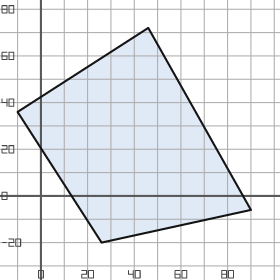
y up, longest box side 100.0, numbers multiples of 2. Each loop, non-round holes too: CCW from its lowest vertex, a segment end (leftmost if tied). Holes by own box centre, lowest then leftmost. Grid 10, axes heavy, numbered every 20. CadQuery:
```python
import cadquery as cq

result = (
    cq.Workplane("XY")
    .moveTo(26.0, -20.0)
    .lineTo(90.0, -6.0)
    .lineTo(46.0, 72.0)
    .lineTo(-10.0, 36.0)
    .close()
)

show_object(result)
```